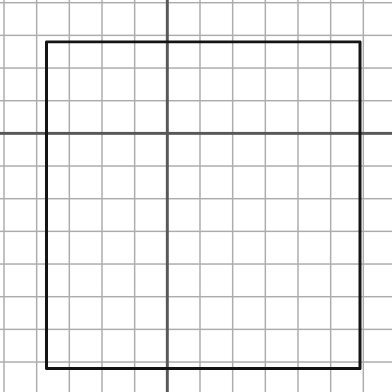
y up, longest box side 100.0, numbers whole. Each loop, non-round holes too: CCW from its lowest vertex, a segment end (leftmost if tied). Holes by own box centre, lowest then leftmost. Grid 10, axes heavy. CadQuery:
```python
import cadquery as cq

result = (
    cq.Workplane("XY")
    .moveTo(-37.0, -72.0)
    .lineTo(59.0, -72.0)
    .lineTo(59.0, 28.0)
    .lineTo(-37.0, 28.0)
    .close()
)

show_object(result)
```